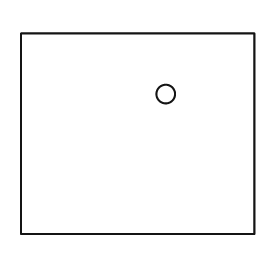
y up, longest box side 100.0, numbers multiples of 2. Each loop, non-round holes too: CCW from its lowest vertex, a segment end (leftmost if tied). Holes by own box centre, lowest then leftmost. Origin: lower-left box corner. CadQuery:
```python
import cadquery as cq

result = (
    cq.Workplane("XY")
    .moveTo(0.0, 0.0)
    .lineTo(100.0, 0.0)
    .lineTo(100.0, 86.0)
    .lineTo(0.0, 86.0)
    .close()
    .moveTo(62.0, 60.0)
    .circle(4.0)
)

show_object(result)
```